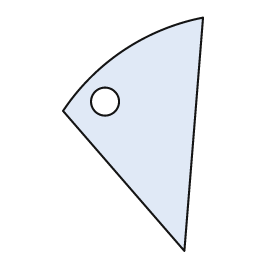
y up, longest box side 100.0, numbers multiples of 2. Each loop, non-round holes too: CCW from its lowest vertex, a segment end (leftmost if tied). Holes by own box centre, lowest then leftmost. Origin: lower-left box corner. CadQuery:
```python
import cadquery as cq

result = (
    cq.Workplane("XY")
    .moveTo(52.0, 0.0)
    .lineTo(60.0, 100.0)
    .threePointArc((26.0, 86.0), (0.0, 60.0))
    .close()
    .moveTo(18.0, 64.0)
    .circle(6.0)
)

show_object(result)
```